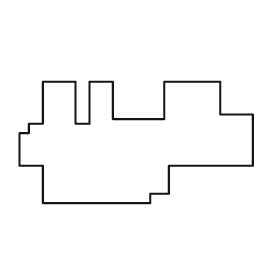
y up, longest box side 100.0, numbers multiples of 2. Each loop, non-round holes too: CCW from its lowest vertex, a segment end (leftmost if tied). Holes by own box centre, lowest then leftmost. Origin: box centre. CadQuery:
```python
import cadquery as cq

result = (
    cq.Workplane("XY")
    .moveTo(-40.0, -26.0)
    .lineTo(6.0, -26.0)
    .lineTo(6.0, -22.0)
    .lineTo(14.0, -22.0)
    .lineTo(14.0, -10.0)
    .lineTo(50.0, -10.0)
    .lineTo(50.0, 12.0)
    .lineTo(36.0, 12.0)
    .lineTo(36.0, 26.0)
    .lineTo(12.0, 26.0)
    .lineTo(12.0, 10.0)
    .lineTo(-10.0, 10.0)
    .lineTo(-10.0, 26.0)
    .lineTo(-20.0, 26.0)
    .lineTo(-20.0, 8.0)
    .lineTo(-26.0, 8.0)
    .lineTo(-26.0, 26.0)
    .lineTo(-40.0, 26.0)
    .lineTo(-40.0, 8.0)
    .lineTo(-46.0, 8.0)
    .lineTo(-46.0, 4.0)
    .lineTo(-50.0, 4.0)
    .lineTo(-50.0, -10.0)
    .lineTo(-40.0, -10.0)
    .close()
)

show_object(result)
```